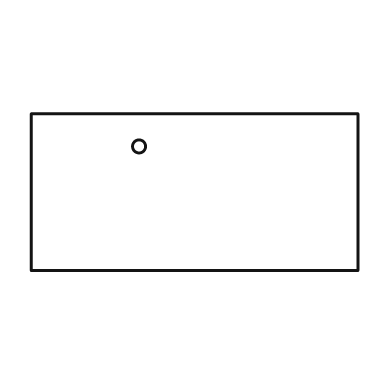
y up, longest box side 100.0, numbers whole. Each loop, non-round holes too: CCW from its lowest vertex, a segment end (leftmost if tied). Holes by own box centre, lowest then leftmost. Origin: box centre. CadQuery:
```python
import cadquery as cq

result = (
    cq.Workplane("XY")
    .moveTo(-50.0, -24.0)
    .lineTo(50.0, -24.0)
    .lineTo(50.0, 24.0)
    .lineTo(-50.0, 24.0)
    .close()
    .moveTo(-17.0, 14.0)
    .circle(2.0)
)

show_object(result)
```